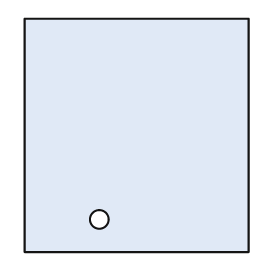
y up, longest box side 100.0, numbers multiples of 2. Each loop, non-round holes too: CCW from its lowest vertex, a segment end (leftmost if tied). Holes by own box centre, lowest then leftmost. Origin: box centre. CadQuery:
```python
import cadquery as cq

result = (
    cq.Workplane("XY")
    .moveTo(-48.0, -50.0)
    .lineTo(48.0, -50.0)
    .lineTo(48.0, 50.0)
    .lineTo(-48.0, 50.0)
    .close()
    .moveTo(-16.0, -36.0)
    .circle(4.0)
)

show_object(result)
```